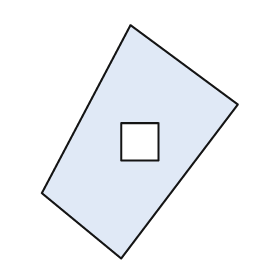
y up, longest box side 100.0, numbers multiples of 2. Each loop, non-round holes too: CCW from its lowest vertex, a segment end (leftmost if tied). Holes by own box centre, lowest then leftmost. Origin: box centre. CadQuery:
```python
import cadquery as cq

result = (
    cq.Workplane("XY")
    .moveTo(-8.0, -50.0)
    .lineTo(42.0, 16.0)
    .lineTo(-4.0, 50.0)
    .lineTo(-42.0, -22.0)
    .close()
    .moveTo(-8.0, -8.0)
    .lineTo(8.0, -8.0)
    .lineTo(8.0, 8.0)
    .lineTo(-8.0, 8.0)
    .close()
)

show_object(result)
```